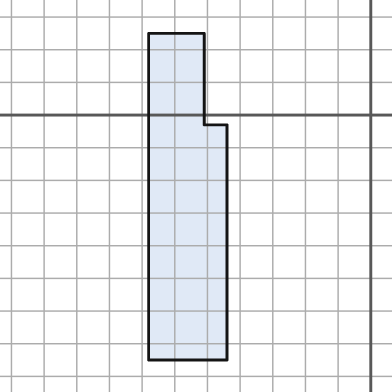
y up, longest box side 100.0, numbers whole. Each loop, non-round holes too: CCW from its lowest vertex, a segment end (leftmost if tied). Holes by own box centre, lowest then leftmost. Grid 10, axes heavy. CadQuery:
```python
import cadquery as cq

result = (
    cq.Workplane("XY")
    .moveTo(-68.0, -75.0)
    .lineTo(-44.0, -75.0)
    .lineTo(-44.0, -3.0)
    .lineTo(-51.0, -3.0)
    .lineTo(-51.0, 25.0)
    .lineTo(-68.0, 25.0)
    .close()
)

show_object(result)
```